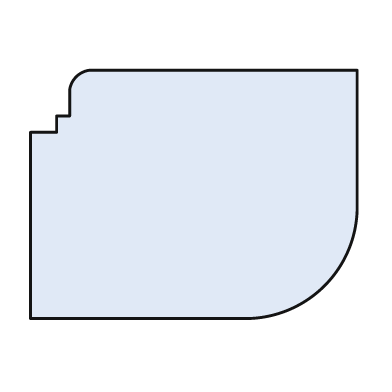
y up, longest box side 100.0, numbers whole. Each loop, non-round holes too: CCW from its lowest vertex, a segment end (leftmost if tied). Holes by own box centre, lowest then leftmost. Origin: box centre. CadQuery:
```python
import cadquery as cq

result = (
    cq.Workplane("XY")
    .moveTo(-50.0, -38.0)
    .lineTo(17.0, -38.0)
    .threePointArc((40.0, -28.0), (50.0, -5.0))
    .lineTo(50.0, 38.0)
    .lineTo(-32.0, 38.0)
    .threePointArc((-36.0, 36.0), (-38.0, 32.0))
    .lineTo(-38.0, 24.0)
    .lineTo(-42.0, 24.0)
    .lineTo(-42.0, 19.0)
    .lineTo(-50.0, 19.0)
    .close()
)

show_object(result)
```